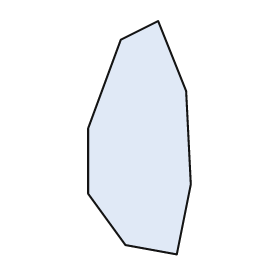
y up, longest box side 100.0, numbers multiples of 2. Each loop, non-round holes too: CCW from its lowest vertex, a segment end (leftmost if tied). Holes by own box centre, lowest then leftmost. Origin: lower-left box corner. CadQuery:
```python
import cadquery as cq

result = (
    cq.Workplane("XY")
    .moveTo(38.0, 0.0)
    .lineTo(44.0, 30.0)
    .lineTo(42.0, 70.0)
    .lineTo(30.0, 100.0)
    .lineTo(14.0, 92.0)
    .lineTo(0.0, 54.0)
    .lineTo(0.0, 26.0)
    .lineTo(16.0, 4.0)
    .close()
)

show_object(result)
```